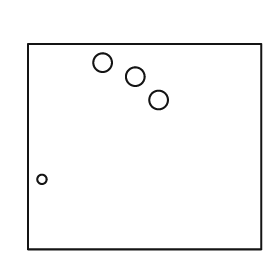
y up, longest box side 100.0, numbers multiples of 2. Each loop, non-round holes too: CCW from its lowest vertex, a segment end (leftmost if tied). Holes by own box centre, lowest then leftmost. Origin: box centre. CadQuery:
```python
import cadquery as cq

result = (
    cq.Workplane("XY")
    .moveTo(-50.0, -44.0)
    .lineTo(50.0, -44.0)
    .lineTo(50.0, 44.0)
    .lineTo(-50.0, 44.0)
    .close()
    .moveTo(-44.0, -14.0)
    .circle(2.0)
    .moveTo(6.0, 20.0)
    .circle(4.0)
    .moveTo(-4.0, 30.0)
    .circle(4.0)
    .moveTo(-18.0, 36.0)
    .circle(4.0)
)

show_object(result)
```